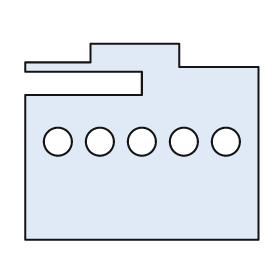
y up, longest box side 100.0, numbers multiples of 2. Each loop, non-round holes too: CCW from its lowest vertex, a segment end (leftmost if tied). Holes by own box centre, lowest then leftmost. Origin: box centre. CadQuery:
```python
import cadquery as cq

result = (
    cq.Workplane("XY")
    .moveTo(-50.0, -42.0)
    .lineTo(50.0, -42.0)
    .lineTo(50.0, 32.0)
    .lineTo(16.0, 32.0)
    .lineTo(16.0, 42.0)
    .lineTo(-22.0, 42.0)
    .lineTo(-22.0, 34.0)
    .lineTo(-50.0, 34.0)
    .lineTo(-50.0, 30.0)
    .lineTo(0.0, 30.0)
    .lineTo(0.0, 20.0)
    .lineTo(-50.0, 20.0)
    .close()
    .moveTo(-36.0, 0.0)
    .circle(6.0)
    .moveTo(-18.0, 0.0)
    .circle(6.0)
    .moveTo(0.0, 0.0)
    .circle(6.0)
    .moveTo(18.0, 0.0)
    .circle(6.0)
    .moveTo(36.0, 0.0)
    .circle(6.0)
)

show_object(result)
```